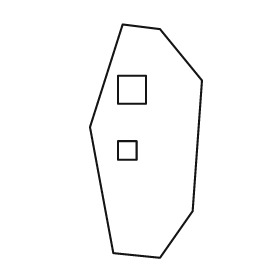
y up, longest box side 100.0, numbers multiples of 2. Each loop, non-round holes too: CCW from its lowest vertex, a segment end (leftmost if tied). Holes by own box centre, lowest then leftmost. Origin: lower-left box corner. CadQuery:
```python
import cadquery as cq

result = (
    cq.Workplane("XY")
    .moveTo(30.0, 0.0)
    .lineTo(44.0, 20.0)
    .lineTo(48.0, 76.0)
    .lineTo(30.0, 98.0)
    .lineTo(14.0, 100.0)
    .lineTo(0.0, 56.0)
    .lineTo(10.0, 2.0)
    .close()
    .moveTo(12.0, 42.0)
    .lineTo(20.0, 42.0)
    .lineTo(20.0, 50.0)
    .lineTo(12.0, 50.0)
    .close()
    .moveTo(12.0, 66.0)
    .lineTo(24.0, 66.0)
    .lineTo(24.0, 78.0)
    .lineTo(12.0, 78.0)
    .close()
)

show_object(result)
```